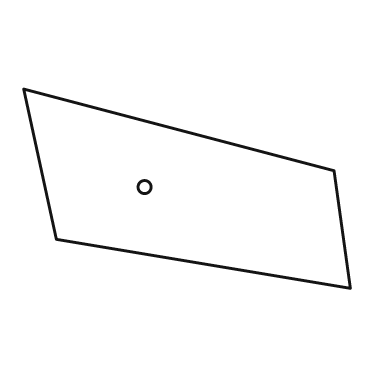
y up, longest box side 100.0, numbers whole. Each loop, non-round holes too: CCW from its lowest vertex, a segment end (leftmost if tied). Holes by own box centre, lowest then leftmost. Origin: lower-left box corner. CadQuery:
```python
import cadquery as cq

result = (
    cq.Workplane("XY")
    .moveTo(100.0, 0.0)
    .lineTo(95.0, 36.0)
    .lineTo(0.0, 61.0)
    .lineTo(10.0, 15.0)
    .close()
    .moveTo(37.0, 31.0)
    .circle(2.0)
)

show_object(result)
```